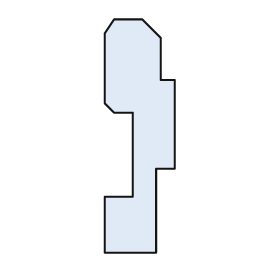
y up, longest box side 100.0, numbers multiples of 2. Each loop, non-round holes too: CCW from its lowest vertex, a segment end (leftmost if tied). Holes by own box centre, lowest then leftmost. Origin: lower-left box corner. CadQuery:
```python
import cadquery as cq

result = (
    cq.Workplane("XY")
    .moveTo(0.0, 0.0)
    .lineTo(22.0, 0.0)
    .lineTo(22.0, 36.0)
    .lineTo(30.0, 36.0)
    .lineTo(30.0, 74.0)
    .lineTo(24.0, 74.0)
    .lineTo(24.0, 92.0)
    .lineTo(16.0, 100.0)
    .lineTo(4.0, 100.0)
    .lineTo(0.0, 94.0)
    .lineTo(0.0, 64.0)
    .lineTo(4.0, 60.0)
    .lineTo(12.0, 60.0)
    .lineTo(12.0, 24.0)
    .lineTo(0.0, 24.0)
    .close()
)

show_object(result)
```